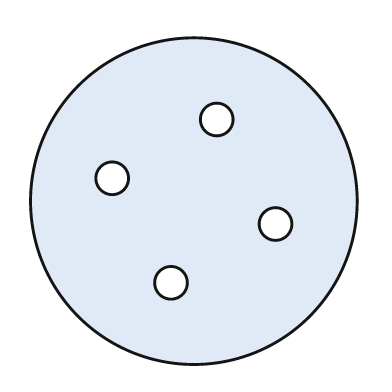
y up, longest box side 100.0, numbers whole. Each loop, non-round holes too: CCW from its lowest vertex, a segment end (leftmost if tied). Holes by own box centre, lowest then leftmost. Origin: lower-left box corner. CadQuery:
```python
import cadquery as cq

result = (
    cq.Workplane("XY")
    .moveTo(50.0, 50.0)
    .circle(50.0)
    .moveTo(43.0, 25.0)
    .circle(5.0)
    .moveTo(75.0, 43.0)
    .circle(5.0)
    .moveTo(25.0, 57.0)
    .circle(5.0)
    .moveTo(57.0, 75.0)
    .circle(5.0)
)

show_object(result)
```